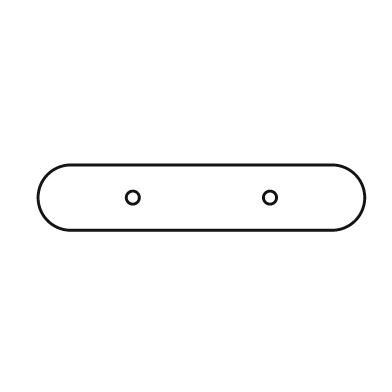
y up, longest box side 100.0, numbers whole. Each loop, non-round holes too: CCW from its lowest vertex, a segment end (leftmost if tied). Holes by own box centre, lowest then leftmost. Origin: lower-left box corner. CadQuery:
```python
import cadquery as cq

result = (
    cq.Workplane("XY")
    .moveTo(10.0, 0.0)
    .lineTo(90.0, 0.0)
    .threePointArc((100.0, 10.0), (90.0, 20.0))
    .lineTo(10.0, 20.0)
    .threePointArc((0.0, 10.0), (10.0, 0.0))
    .close()
    .moveTo(29.0, 10.0)
    .circle(2.0)
    .moveTo(71.0, 10.0)
    .circle(2.0)
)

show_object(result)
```